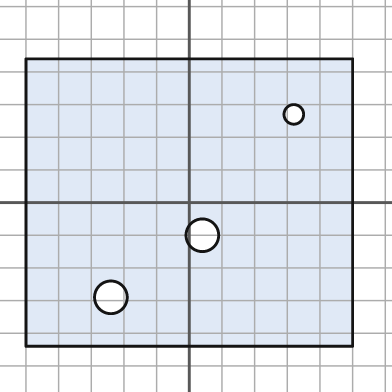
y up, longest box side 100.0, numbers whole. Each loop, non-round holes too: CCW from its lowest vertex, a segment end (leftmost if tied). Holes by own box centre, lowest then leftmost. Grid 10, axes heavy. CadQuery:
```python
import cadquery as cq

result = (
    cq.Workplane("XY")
    .moveTo(-50.0, -44.0)
    .lineTo(50.0, -44.0)
    .lineTo(50.0, 44.0)
    .lineTo(-50.0, 44.0)
    .close()
    .moveTo(-24.0, -29.0)
    .circle(5.0)
    .moveTo(4.0, -10.0)
    .circle(5.0)
    .moveTo(32.0, 27.0)
    .circle(3.0)
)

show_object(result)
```